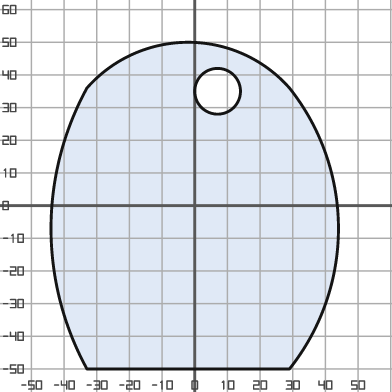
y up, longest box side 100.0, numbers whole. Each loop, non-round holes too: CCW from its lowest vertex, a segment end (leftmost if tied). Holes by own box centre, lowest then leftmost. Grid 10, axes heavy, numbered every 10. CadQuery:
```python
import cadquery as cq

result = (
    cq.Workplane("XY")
    .moveTo(-33.0, -50.0)
    .lineTo(29.0, -50.0)
    .threePointArc((44.0, -7.0), (29.0, 36.0))
    .threePointArc((-2.0, 50.0), (-33.0, 36.0))
    .threePointArc((-44.0, -7.0), (-33.0, -50.0))
    .close()
    .moveTo(7.0, 35.0)
    .circle(7.0)
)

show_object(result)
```